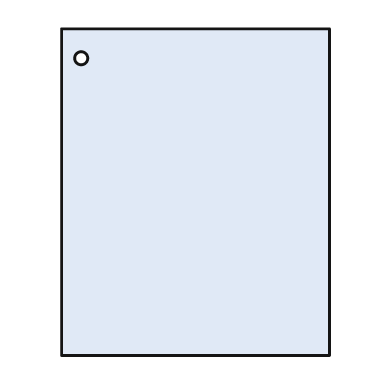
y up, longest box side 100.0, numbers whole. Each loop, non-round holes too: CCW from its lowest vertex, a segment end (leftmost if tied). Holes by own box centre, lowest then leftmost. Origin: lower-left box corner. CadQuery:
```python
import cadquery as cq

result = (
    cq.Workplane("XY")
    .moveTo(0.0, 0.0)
    .lineTo(82.0, 0.0)
    .lineTo(82.0, 100.0)
    .lineTo(0.0, 100.0)
    .close()
    .moveTo(6.0, 91.0)
    .circle(2.0)
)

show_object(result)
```